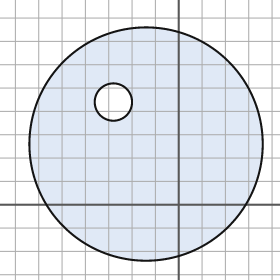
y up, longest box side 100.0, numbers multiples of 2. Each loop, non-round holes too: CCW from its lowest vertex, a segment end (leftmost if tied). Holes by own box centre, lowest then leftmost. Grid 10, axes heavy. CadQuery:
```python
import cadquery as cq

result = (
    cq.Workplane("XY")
    .moveTo(-14.0, 26.0)
    .circle(50.0)
    .moveTo(-28.0, 44.0)
    .circle(8.0)
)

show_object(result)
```